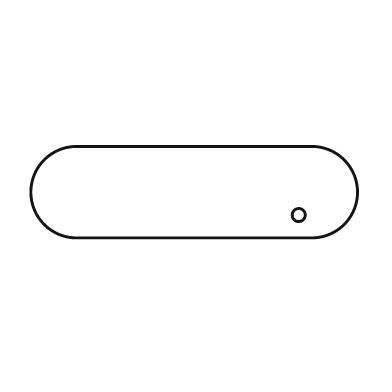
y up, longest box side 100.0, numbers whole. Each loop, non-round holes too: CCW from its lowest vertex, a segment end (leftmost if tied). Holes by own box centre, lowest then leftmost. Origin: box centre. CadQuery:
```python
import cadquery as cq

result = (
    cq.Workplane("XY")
    .moveTo(-36.0, -14.0)
    .lineTo(36.0, -14.0)
    .threePointArc((50.0, 0.0), (36.0, 14.0))
    .lineTo(-36.0, 14.0)
    .threePointArc((-50.0, 0.0), (-36.0, -14.0))
    .close()
    .moveTo(32.0, -7.0)
    .circle(2.0)
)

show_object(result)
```